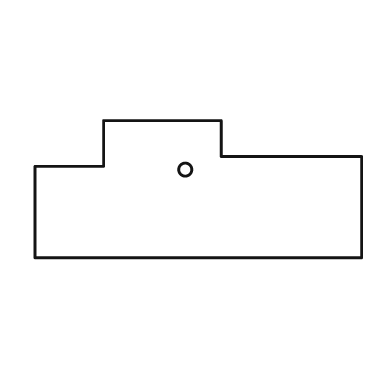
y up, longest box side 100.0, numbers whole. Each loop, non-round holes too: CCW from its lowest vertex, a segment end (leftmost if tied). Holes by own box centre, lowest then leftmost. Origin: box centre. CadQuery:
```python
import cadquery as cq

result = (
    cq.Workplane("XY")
    .moveTo(-50.0, -21.0)
    .lineTo(50.0, -21.0)
    .lineTo(50.0, 10.0)
    .lineTo(7.0, 10.0)
    .lineTo(7.0, 21.0)
    .lineTo(-29.0, 21.0)
    .lineTo(-29.0, 7.0)
    .lineTo(-50.0, 7.0)
    .close()
    .moveTo(-4.0, 6.0)
    .circle(2.0)
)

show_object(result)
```